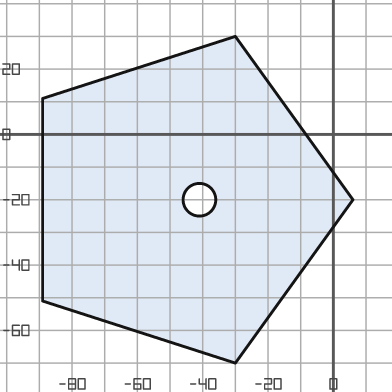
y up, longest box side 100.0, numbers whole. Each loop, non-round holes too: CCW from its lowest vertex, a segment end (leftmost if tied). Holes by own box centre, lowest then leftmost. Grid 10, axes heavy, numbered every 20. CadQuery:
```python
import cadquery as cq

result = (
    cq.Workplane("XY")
    .moveTo(-30.0, -70.0)
    .lineTo(6.0, -20.0)
    .lineTo(-30.0, 30.0)
    .lineTo(-89.0, 11.0)
    .lineTo(-89.0, -51.0)
    .close()
    .moveTo(-41.0, -20.0)
    .circle(5.0)
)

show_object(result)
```